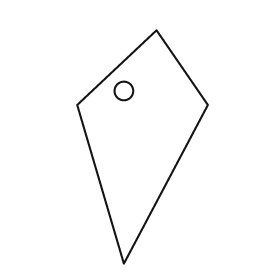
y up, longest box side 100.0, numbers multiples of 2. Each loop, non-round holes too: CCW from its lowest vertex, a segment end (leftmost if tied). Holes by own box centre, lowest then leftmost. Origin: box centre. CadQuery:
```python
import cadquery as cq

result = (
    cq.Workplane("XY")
    .moveTo(-8.0, -50.0)
    .lineTo(28.0, 18.0)
    .lineTo(6.0, 50.0)
    .lineTo(-28.0, 18.0)
    .close()
    .moveTo(-8.0, 24.0)
    .circle(4.0)
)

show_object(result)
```